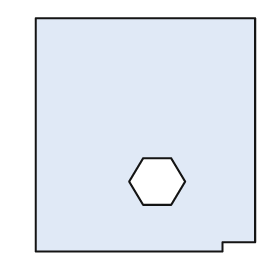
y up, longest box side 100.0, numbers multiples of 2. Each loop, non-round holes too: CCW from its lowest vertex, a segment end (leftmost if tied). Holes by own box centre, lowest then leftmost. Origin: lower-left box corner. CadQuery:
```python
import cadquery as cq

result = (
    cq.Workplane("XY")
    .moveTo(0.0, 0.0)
    .lineTo(80.0, 0.0)
    .lineTo(80.0, 4.0)
    .lineTo(94.0, 4.0)
    .lineTo(94.0, 100.0)
    .lineTo(0.0, 100.0)
    .close()
    .moveTo(46.0, 20.0)
    .lineTo(58.0, 20.0)
    .lineTo(64.0, 30.0)
    .lineTo(58.0, 40.0)
    .lineTo(46.0, 40.0)
    .lineTo(40.0, 30.0)
    .close()
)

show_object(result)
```